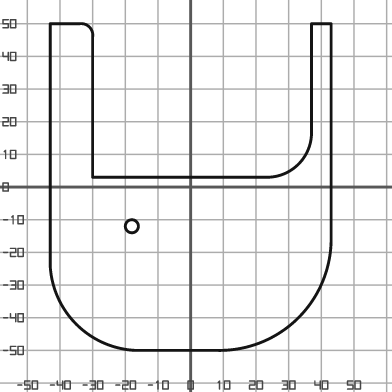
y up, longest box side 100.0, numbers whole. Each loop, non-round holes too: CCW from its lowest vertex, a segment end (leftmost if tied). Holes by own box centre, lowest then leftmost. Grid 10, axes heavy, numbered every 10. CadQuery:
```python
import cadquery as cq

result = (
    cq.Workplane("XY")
    .moveTo(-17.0, -50.0)
    .lineTo(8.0, -50.0)
    .threePointArc((33.0, -40.0), (43.0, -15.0))
    .lineTo(43.0, 50.0)
    .lineTo(37.0, 50.0)
    .lineTo(37.0, 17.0)
    .threePointArc((33.0, 7.0), (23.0, 3.0))
    .lineTo(-30.0, 3.0)
    .lineTo(-30.0, 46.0)
    .threePointArc((-31.0, 49.0), (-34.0, 50.0))
    .lineTo(-43.0, 50.0)
    .lineTo(-43.0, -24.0)
    .threePointArc((-35.0, -42.0), (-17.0, -50.0))
    .close()
    .moveTo(-18.0, -12.0)
    .circle(2.0)
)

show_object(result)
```